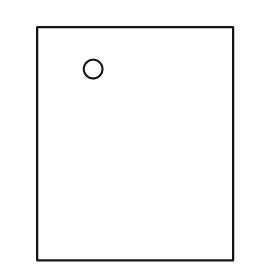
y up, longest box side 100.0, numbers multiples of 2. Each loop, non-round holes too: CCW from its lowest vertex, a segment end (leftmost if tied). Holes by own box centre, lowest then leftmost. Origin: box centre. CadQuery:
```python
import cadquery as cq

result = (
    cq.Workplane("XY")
    .moveTo(-42.0, -50.0)
    .lineTo(42.0, -50.0)
    .lineTo(42.0, 50.0)
    .lineTo(-42.0, 50.0)
    .close()
    .moveTo(-18.0, 32.0)
    .circle(4.0)
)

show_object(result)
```